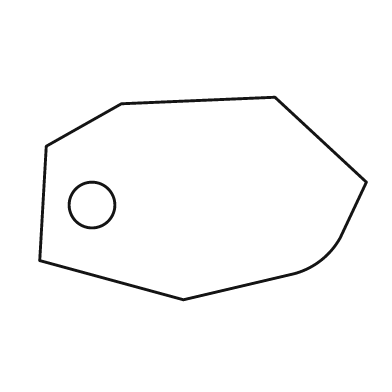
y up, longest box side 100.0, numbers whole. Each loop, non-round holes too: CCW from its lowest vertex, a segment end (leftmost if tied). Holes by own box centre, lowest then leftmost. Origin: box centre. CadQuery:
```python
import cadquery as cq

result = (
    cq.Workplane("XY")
    .moveTo(-6.0, -31.0)
    .lineTo(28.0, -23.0)
    .threePointArc((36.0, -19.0), (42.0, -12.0))
    .lineTo(50.0, 5.0)
    .lineTo(22.0, 31.0)
    .lineTo(-25.0, 29.0)
    .lineTo(-48.0, 16.0)
    .lineTo(-50.0, -19.0)
    .close()
    .moveTo(-34.0, -2.0)
    .circle(7.0)
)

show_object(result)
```